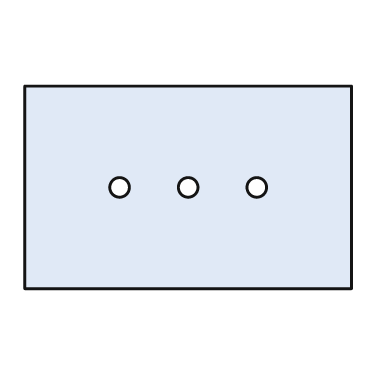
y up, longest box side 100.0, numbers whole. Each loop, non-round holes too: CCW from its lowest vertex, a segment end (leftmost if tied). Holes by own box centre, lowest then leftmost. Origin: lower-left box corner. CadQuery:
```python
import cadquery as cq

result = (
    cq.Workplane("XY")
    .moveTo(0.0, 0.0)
    .lineTo(100.0, 0.0)
    .lineTo(100.0, 62.0)
    .lineTo(0.0, 62.0)
    .close()
    .moveTo(29.0, 31.0)
    .circle(3.0)
    .moveTo(50.0, 31.0)
    .circle(3.0)
    .moveTo(71.0, 31.0)
    .circle(3.0)
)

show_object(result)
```